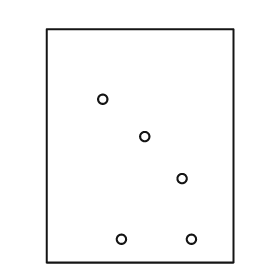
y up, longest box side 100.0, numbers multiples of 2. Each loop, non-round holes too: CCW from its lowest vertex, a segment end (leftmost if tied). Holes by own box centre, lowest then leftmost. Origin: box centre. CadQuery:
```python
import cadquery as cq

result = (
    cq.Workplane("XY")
    .moveTo(-40.0, -50.0)
    .lineTo(40.0, -50.0)
    .lineTo(40.0, 50.0)
    .lineTo(-40.0, 50.0)
    .close()
    .moveTo(-8.0, -40.0)
    .circle(2.0)
    .moveTo(22.0, -40.0)
    .circle(2.0)
    .moveTo(18.0, -14.0)
    .circle(2.0)
    .moveTo(2.0, 4.0)
    .circle(2.0)
    .moveTo(-16.0, 20.0)
    .circle(2.0)
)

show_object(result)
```